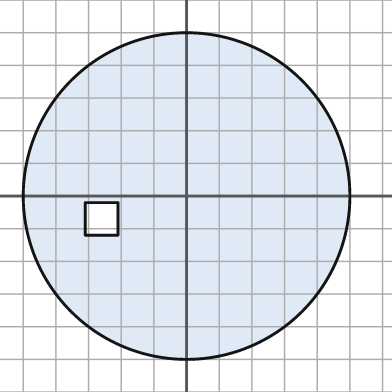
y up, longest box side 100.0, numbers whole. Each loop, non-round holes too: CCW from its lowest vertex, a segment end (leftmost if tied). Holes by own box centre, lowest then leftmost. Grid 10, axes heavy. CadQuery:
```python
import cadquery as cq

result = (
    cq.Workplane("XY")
    .moveTo(0.0, 0.0)
    .circle(50.0)
    .moveTo(-31.0, -12.0)
    .lineTo(-21.0, -12.0)
    .lineTo(-21.0, -2.0)
    .lineTo(-31.0, -2.0)
    .close()
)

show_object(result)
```